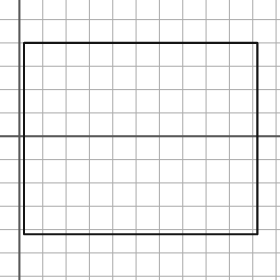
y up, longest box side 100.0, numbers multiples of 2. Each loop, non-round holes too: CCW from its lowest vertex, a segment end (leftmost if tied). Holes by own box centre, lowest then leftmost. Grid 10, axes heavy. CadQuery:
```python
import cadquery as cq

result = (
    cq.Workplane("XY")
    .moveTo(2.0, -42.0)
    .lineTo(102.0, -42.0)
    .lineTo(102.0, 40.0)
    .lineTo(2.0, 40.0)
    .close()
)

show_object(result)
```